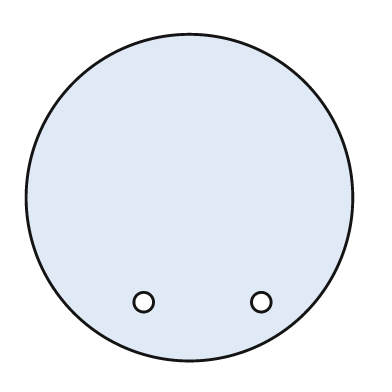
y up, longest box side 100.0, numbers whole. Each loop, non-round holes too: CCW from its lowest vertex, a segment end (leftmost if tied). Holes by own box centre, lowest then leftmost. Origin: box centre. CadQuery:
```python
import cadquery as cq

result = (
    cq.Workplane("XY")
    .moveTo(0.0, 0.0)
    .circle(50.0)
    .moveTo(-14.0, -32.0)
    .circle(3.0)
    .moveTo(22.0, -32.0)
    .circle(3.0)
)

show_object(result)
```